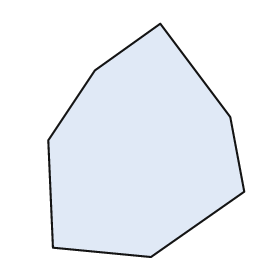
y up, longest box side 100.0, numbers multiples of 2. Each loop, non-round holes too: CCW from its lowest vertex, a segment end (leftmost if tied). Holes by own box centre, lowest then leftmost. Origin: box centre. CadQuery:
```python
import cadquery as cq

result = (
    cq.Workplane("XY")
    .moveTo(2.0, -50.0)
    .lineTo(42.0, -22.0)
    .lineTo(36.0, 10.0)
    .lineTo(6.0, 50.0)
    .lineTo(-22.0, 30.0)
    .lineTo(-42.0, 0.0)
    .lineTo(-40.0, -46.0)
    .close()
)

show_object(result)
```